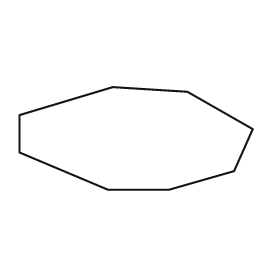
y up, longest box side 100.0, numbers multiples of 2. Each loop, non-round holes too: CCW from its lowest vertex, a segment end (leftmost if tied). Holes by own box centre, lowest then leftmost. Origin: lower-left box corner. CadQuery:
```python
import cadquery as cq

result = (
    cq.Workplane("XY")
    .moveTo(38.0, 0.0)
    .lineTo(64.0, 0.0)
    .lineTo(92.0, 8.0)
    .lineTo(100.0, 26.0)
    .lineTo(72.0, 42.0)
    .lineTo(40.0, 44.0)
    .lineTo(0.0, 32.0)
    .lineTo(0.0, 16.0)
    .close()
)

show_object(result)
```